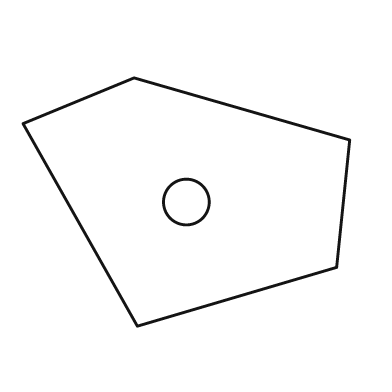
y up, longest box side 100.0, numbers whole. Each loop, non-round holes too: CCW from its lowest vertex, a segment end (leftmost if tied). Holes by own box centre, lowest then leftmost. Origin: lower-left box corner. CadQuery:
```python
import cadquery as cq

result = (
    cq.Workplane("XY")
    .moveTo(35.0, 0.0)
    .lineTo(96.0, 18.0)
    .lineTo(100.0, 57.0)
    .lineTo(34.0, 76.0)
    .lineTo(0.0, 62.0)
    .close()
    .moveTo(50.0, 38.0)
    .circle(7.0)
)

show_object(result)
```